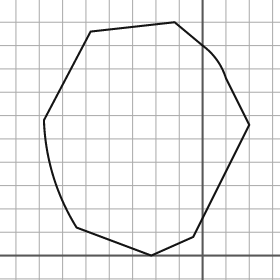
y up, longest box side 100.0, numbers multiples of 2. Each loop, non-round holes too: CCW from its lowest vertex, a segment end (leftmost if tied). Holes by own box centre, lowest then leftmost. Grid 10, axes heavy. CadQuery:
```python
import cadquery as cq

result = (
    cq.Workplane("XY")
    .moveTo(-22.0, 0.0)
    .lineTo(-4.0, 8.0)
    .lineTo(20.0, 56.0)
    .lineTo(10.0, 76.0)
    .threePointArc((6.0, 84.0), (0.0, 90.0))
    .lineTo(-12.0, 100.0)
    .lineTo(-48.0, 96.0)
    .lineTo(-68.0, 58.0)
    .threePointArc((-64.0, 34.0), (-54.0, 12.0))
    .close()
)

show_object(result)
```